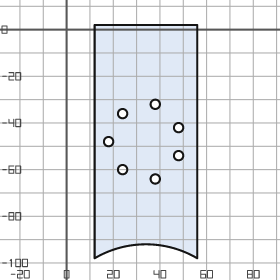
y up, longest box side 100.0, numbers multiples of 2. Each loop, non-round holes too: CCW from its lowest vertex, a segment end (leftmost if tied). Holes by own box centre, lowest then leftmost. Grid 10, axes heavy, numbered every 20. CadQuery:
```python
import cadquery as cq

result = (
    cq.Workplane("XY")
    .moveTo(12.0, -98.0)
    .threePointArc((34.0, -92.0), (56.0, -98.0))
    .lineTo(56.0, 2.0)
    .lineTo(12.0, 2.0)
    .close()
    .moveTo(38.0, -64.0)
    .circle(2.0)
    .moveTo(24.0, -60.0)
    .circle(2.0)
    .moveTo(48.0, -54.0)
    .circle(2.0)
    .moveTo(18.0, -48.0)
    .circle(2.0)
    .moveTo(48.0, -42.0)
    .circle(2.0)
    .moveTo(24.0, -36.0)
    .circle(2.0)
    .moveTo(38.0, -32.0)
    .circle(2.0)
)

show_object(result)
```